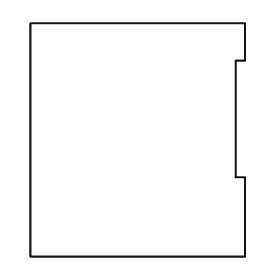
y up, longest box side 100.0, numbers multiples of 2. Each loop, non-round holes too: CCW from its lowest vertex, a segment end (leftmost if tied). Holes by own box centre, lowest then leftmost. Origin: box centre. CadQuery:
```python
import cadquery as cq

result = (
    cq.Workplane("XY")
    .moveTo(-46.0, -50.0)
    .lineTo(46.0, -50.0)
    .lineTo(46.0, -16.0)
    .lineTo(42.0, -16.0)
    .lineTo(42.0, 34.0)
    .lineTo(46.0, 34.0)
    .lineTo(46.0, 50.0)
    .lineTo(-46.0, 50.0)
    .close()
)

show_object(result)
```